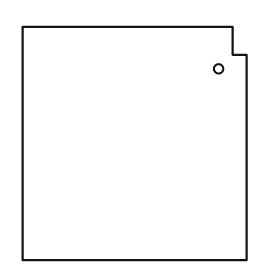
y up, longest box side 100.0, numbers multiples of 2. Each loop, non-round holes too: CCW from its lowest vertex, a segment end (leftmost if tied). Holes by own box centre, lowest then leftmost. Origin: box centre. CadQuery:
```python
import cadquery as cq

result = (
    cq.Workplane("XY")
    .moveTo(-48.0, -50.0)
    .lineTo(48.0, -50.0)
    .lineTo(48.0, 38.0)
    .lineTo(42.0, 38.0)
    .lineTo(42.0, 50.0)
    .lineTo(-48.0, 50.0)
    .close()
    .moveTo(36.0, 32.0)
    .circle(2.0)
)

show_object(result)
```